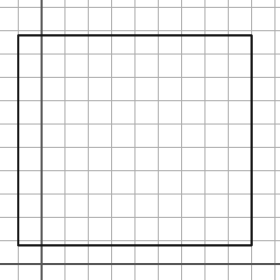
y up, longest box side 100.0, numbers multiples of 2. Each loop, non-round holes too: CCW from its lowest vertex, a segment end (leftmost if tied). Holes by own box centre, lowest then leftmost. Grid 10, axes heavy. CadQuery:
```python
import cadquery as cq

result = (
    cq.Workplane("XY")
    .moveTo(-10.0, 8.0)
    .lineTo(90.0, 8.0)
    .lineTo(90.0, 98.0)
    .lineTo(-10.0, 98.0)
    .close()
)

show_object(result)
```